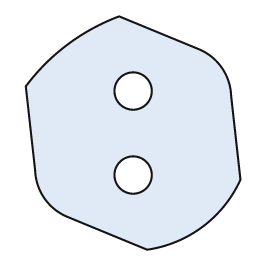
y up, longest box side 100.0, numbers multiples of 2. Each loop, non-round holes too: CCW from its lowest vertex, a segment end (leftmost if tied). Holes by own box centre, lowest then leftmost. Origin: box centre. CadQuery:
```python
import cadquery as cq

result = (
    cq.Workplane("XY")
    .moveTo(6.0, -50.0)
    .threePointArc((30.0, -40.0), (46.0, -20.0))
    .lineTo(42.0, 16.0)
    .threePointArc((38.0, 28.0), (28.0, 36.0))
    .lineTo(-6.0, 50.0)
    .threePointArc((-28.0, 38.0), (-46.0, 20.0))
    .lineTo(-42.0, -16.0)
    .threePointArc((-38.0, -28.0), (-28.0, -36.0))
    .close()
    .moveTo(0.0, -18.0)
    .circle(8.0)
    .moveTo(0.0, 18.0)
    .circle(8.0)
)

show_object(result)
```